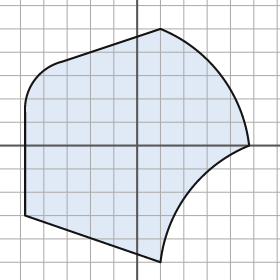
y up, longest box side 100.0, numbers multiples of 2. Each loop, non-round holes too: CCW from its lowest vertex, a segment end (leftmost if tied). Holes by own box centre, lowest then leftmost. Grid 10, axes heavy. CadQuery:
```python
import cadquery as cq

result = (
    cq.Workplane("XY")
    .moveTo(10.0, -50.0)
    .threePointArc((22.0, -20.0), (48.0, 0.0))
    .threePointArc((36.0, 30.0), (10.0, 50.0))
    .lineTo(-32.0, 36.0)
    .threePointArc((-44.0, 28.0), (-48.0, 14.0))
    .lineTo(-48.0, -30.0)
    .close()
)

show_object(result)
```